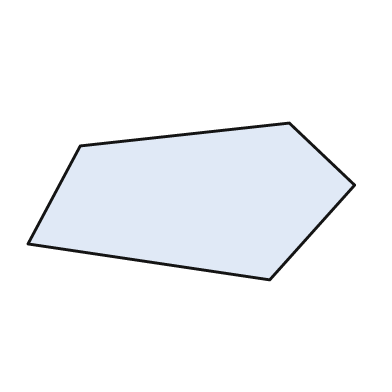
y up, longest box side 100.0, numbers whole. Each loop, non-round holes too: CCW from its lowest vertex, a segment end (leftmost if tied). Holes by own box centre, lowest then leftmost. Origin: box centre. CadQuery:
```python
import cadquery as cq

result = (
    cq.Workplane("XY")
    .moveTo(24.0, -24.0)
    .lineTo(50.0, 5.0)
    .lineTo(30.0, 24.0)
    .lineTo(-34.0, 17.0)
    .lineTo(-50.0, -13.0)
    .close()
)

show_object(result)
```